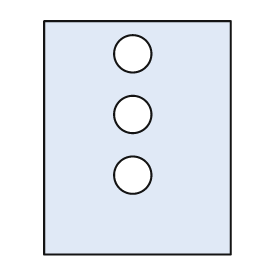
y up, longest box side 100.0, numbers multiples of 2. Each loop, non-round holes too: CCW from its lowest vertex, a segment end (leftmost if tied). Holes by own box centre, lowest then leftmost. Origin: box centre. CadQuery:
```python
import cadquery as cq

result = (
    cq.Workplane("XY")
    .moveTo(-40.0, -50.0)
    .lineTo(40.0, -50.0)
    .lineTo(40.0, 50.0)
    .lineTo(-40.0, 50.0)
    .close()
    .moveTo(-2.0, -16.0)
    .circle(8.0)
    .moveTo(-2.0, 10.0)
    .circle(8.0)
    .moveTo(-2.0, 36.0)
    .circle(8.0)
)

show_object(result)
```